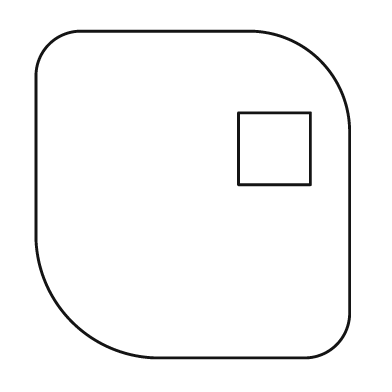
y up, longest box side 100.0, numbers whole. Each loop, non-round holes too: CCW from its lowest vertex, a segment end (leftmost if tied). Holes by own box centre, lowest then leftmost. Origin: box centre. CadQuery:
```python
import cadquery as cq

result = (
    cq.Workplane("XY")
    .moveTo(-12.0, -50.0)
    .lineTo(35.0, -50.0)
    .threePointArc((44.0, -46.0), (48.0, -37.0))
    .lineTo(48.0, 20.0)
    .threePointArc((39.0, 41.0), (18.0, 50.0))
    .lineTo(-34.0, 50.0)
    .threePointArc((-44.0, 46.0), (-48.0, 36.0))
    .lineTo(-48.0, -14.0)
    .threePointArc((-37.0, -39.0), (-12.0, -50.0))
    .close()
    .moveTo(14.0, 3.0)
    .lineTo(36.0, 3.0)
    .lineTo(36.0, 25.0)
    .lineTo(14.0, 25.0)
    .close()
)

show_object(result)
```